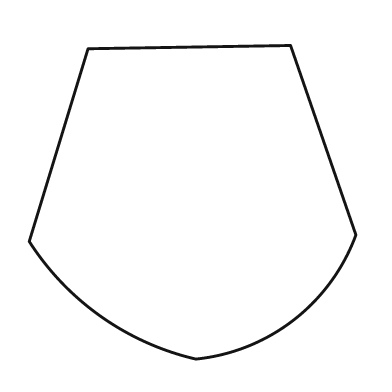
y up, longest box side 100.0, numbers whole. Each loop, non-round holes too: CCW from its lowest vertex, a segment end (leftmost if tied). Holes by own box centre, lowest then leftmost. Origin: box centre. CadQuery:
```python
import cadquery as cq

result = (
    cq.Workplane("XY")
    .moveTo(1.0, -48.0)
    .threePointArc((31.0, -36.0), (50.0, -10.0))
    .lineTo(30.0, 48.0)
    .lineTo(-32.0, 47.0)
    .lineTo(-50.0, -12.0)
    .threePointArc((-28.0, -35.0), (1.0, -48.0))
    .close()
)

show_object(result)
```